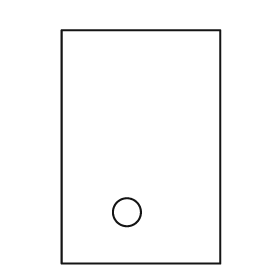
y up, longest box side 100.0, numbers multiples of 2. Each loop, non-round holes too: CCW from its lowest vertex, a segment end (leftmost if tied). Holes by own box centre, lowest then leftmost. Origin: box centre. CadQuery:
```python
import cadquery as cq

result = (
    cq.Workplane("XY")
    .moveTo(-34.0, -50.0)
    .lineTo(34.0, -50.0)
    .lineTo(34.0, 50.0)
    .lineTo(-34.0, 50.0)
    .close()
    .moveTo(-6.0, -28.0)
    .circle(6.0)
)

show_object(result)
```